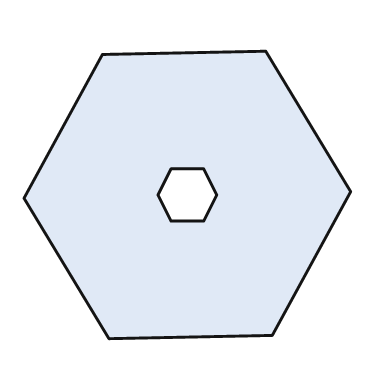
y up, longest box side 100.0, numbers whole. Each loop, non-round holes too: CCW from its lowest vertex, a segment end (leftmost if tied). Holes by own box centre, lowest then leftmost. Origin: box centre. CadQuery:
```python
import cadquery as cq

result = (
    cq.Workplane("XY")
    .moveTo(-24.0, -44.0)
    .lineTo(26.0, -43.0)
    .lineTo(50.0, 1.0)
    .lineTo(24.0, 44.0)
    .lineTo(-26.0, 43.0)
    .lineTo(-50.0, -1.0)
    .close()
    .moveTo(-5.0, -8.0)
    .lineTo(5.0, -8.0)
    .lineTo(9.0, 0.0)
    .lineTo(5.0, 8.0)
    .lineTo(-5.0, 8.0)
    .lineTo(-9.0, 0.0)
    .close()
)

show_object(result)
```